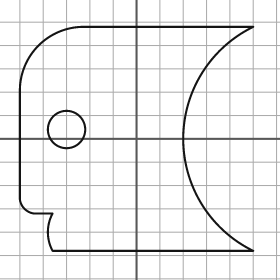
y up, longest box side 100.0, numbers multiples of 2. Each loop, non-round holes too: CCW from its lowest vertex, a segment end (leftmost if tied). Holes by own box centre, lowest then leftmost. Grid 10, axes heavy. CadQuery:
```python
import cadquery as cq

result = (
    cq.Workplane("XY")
    .moveTo(-36.0, -48.0)
    .lineTo(50.0, -48.0)
    .threePointArc((20.0, 0.0), (50.0, 48.0))
    .lineTo(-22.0, 48.0)
    .threePointArc((-42.0, 40.0), (-50.0, 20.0))
    .lineTo(-50.0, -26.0)
    .threePointArc((-48.0, -30.0), (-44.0, -32.0))
    .lineTo(-36.0, -32.0)
    .threePointArc((-38.0, -40.0), (-36.0, -48.0))
    .close()
    .moveTo(-30.0, 4.0)
    .circle(8.0)
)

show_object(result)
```